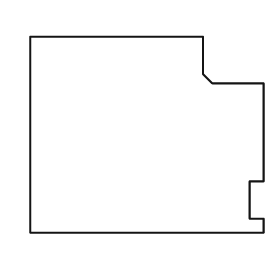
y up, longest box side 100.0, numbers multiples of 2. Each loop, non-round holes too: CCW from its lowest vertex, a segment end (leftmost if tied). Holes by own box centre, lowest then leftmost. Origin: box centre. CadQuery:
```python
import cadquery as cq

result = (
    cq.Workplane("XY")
    .moveTo(-50.0, -42.0)
    .lineTo(50.0, -42.0)
    .lineTo(50.0, -36.0)
    .lineTo(44.0, -36.0)
    .lineTo(44.0, -20.0)
    .lineTo(50.0, -20.0)
    .lineTo(50.0, 22.0)
    .lineTo(28.0, 22.0)
    .lineTo(24.0, 26.0)
    .lineTo(24.0, 42.0)
    .lineTo(-50.0, 42.0)
    .close()
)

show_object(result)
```